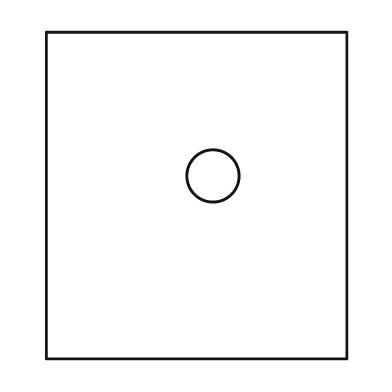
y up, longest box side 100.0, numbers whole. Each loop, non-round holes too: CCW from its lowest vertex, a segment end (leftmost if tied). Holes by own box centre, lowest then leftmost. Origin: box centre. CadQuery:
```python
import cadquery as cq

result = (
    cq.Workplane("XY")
    .moveTo(-46.0, -50.0)
    .lineTo(46.0, -50.0)
    .lineTo(46.0, 50.0)
    .lineTo(-46.0, 50.0)
    .close()
    .moveTo(5.0, 6.0)
    .circle(8.0)
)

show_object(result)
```